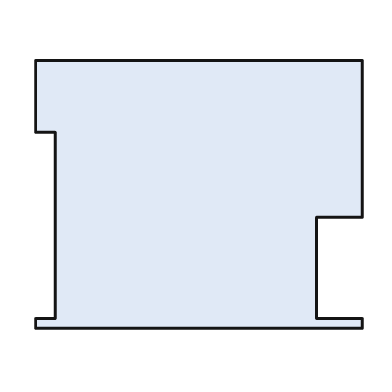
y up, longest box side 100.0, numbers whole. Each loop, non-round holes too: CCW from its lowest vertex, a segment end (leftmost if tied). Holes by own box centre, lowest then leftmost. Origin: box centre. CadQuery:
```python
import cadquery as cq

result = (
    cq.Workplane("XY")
    .moveTo(-50.0, -41.0)
    .lineTo(50.0, -41.0)
    .lineTo(50.0, -38.0)
    .lineTo(36.0, -38.0)
    .lineTo(36.0, -7.0)
    .lineTo(50.0, -7.0)
    .lineTo(50.0, 41.0)
    .lineTo(-50.0, 41.0)
    .lineTo(-50.0, 19.0)
    .lineTo(-44.0, 19.0)
    .lineTo(-44.0, -38.0)
    .lineTo(-50.0, -38.0)
    .close()
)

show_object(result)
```